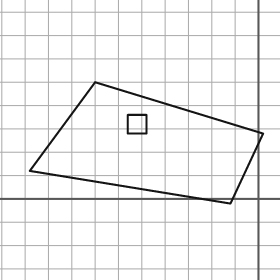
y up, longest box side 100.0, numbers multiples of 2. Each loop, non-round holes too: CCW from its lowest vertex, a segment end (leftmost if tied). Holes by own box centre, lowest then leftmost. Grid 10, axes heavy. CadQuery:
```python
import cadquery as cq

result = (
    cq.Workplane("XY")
    .moveTo(-12.0, -2.0)
    .lineTo(2.0, 28.0)
    .lineTo(-70.0, 50.0)
    .lineTo(-98.0, 12.0)
    .close()
    .moveTo(-56.0, 28.0)
    .lineTo(-48.0, 28.0)
    .lineTo(-48.0, 36.0)
    .lineTo(-56.0, 36.0)
    .close()
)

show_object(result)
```